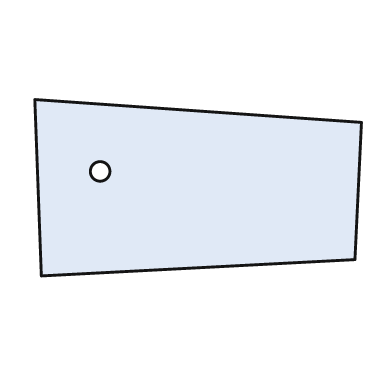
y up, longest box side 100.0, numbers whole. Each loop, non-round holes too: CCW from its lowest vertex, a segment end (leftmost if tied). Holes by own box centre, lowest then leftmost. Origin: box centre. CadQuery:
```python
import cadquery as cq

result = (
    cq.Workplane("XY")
    .moveTo(-48.0, -27.0)
    .lineTo(48.0, -22.0)
    .lineTo(50.0, 20.0)
    .lineTo(-50.0, 27.0)
    .close()
    .moveTo(-30.0, 5.0)
    .circle(3.0)
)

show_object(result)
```